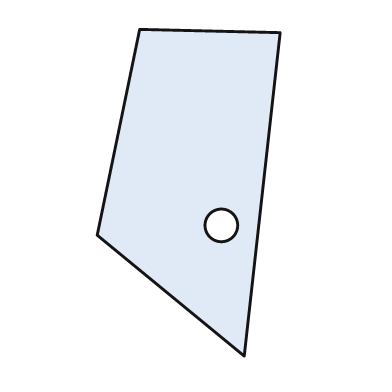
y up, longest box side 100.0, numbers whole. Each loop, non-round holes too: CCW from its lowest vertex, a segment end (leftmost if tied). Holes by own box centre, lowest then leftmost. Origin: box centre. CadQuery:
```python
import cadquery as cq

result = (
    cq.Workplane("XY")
    .moveTo(17.0, -50.0)
    .lineTo(28.0, 49.0)
    .lineTo(-15.0, 50.0)
    .lineTo(-28.0, -13.0)
    .close()
    .moveTo(10.0, -10.0)
    .circle(5.0)
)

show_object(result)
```